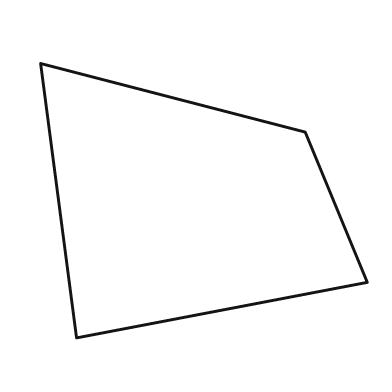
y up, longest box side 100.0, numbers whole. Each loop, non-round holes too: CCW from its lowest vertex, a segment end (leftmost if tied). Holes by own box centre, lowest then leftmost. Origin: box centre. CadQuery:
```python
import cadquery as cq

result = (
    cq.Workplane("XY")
    .moveTo(-39.0, -42.0)
    .lineTo(50.0, -25.0)
    .lineTo(31.0, 21.0)
    .lineTo(-50.0, 42.0)
    .close()
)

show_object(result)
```